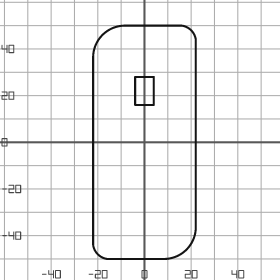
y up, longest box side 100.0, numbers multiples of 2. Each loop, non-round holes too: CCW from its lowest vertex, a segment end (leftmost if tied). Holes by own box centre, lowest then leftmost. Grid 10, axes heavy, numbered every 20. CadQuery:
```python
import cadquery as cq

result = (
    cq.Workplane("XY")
    .moveTo(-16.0, -50.0)
    .lineTo(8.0, -50.0)
    .threePointArc((18.0, -46.0), (22.0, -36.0))
    .lineTo(22.0, 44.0)
    .threePointArc((20.0, 48.0), (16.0, 50.0))
    .lineTo(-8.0, 50.0)
    .threePointArc((-18.0, 46.0), (-22.0, 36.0))
    .lineTo(-22.0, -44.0)
    .threePointArc((-20.0, -48.0), (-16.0, -50.0))
    .close()
    .moveTo(-4.0, 16.0)
    .lineTo(4.0, 16.0)
    .lineTo(4.0, 28.0)
    .lineTo(-4.0, 28.0)
    .close()
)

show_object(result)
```